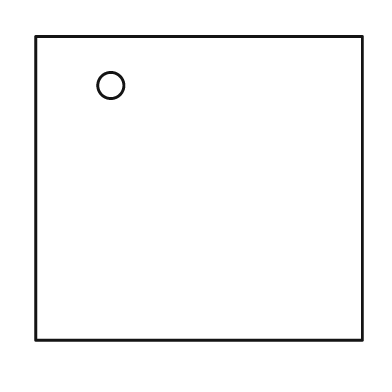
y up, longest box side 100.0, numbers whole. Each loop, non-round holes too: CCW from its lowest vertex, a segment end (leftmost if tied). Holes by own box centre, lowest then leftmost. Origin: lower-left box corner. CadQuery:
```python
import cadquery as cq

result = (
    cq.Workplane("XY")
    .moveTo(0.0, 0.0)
    .lineTo(100.0, 0.0)
    .lineTo(100.0, 93.0)
    .lineTo(0.0, 93.0)
    .close()
    .moveTo(23.0, 78.0)
    .circle(4.0)
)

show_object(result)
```